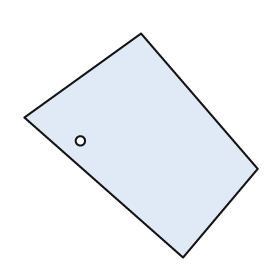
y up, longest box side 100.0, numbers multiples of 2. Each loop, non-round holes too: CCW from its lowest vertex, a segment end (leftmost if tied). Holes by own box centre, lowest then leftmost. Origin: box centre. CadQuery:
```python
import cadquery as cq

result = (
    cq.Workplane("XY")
    .moveTo(18.0, -48.0)
    .lineTo(50.0, -10.0)
    .lineTo(0.0, 48.0)
    .lineTo(-50.0, 12.0)
    .close()
    .moveTo(-26.0, 2.0)
    .circle(2.0)
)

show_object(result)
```